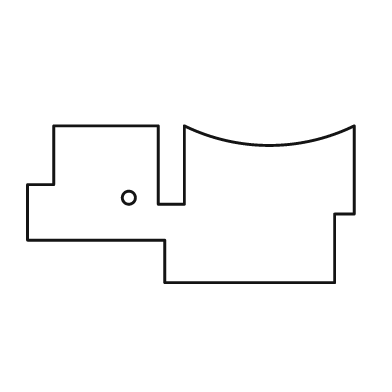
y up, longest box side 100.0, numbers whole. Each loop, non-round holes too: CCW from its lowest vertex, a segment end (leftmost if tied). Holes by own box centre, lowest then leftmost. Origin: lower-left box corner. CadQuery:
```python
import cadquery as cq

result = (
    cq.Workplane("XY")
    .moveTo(42.0, 0.0)
    .lineTo(94.0, 0.0)
    .lineTo(94.0, 21.0)
    .lineTo(100.0, 21.0)
    .lineTo(100.0, 48.0)
    .threePointArc((74.0, 42.0), (48.0, 48.0))
    .lineTo(48.0, 24.0)
    .lineTo(40.0, 24.0)
    .lineTo(40.0, 48.0)
    .lineTo(8.0, 48.0)
    .lineTo(8.0, 30.0)
    .lineTo(0.0, 30.0)
    .lineTo(0.0, 13.0)
    .lineTo(42.0, 13.0)
    .close()
    .moveTo(31.0, 26.0)
    .circle(2.0)
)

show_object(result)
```